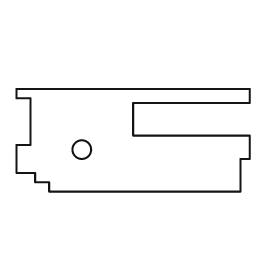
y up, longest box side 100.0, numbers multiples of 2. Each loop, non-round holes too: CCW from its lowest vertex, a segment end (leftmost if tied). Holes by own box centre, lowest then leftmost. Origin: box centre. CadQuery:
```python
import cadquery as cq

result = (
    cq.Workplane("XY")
    .moveTo(-36.0, -22.0)
    .lineTo(46.0, -22.0)
    .lineTo(46.0, -8.0)
    .lineTo(50.0, -8.0)
    .lineTo(50.0, 2.0)
    .lineTo(0.0, 2.0)
    .lineTo(0.0, 16.0)
    .lineTo(50.0, 16.0)
    .lineTo(50.0, 22.0)
    .lineTo(-50.0, 22.0)
    .lineTo(-50.0, 18.0)
    .lineTo(-44.0, 18.0)
    .lineTo(-44.0, -2.0)
    .lineTo(-50.0, -2.0)
    .lineTo(-50.0, -14.0)
    .lineTo(-42.0, -14.0)
    .lineTo(-42.0, -18.0)
    .lineTo(-36.0, -18.0)
    .close()
    .moveTo(-22.0, -4.0)
    .circle(4.0)
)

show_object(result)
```